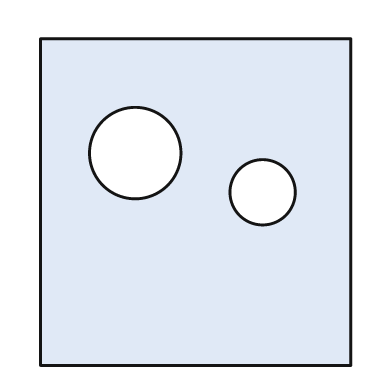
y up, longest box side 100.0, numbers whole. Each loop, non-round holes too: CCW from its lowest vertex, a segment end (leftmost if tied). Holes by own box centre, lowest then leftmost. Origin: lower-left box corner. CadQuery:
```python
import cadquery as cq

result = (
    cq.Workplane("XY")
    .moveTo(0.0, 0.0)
    .lineTo(95.0, 0.0)
    .lineTo(95.0, 100.0)
    .lineTo(0.0, 100.0)
    .close()
    .moveTo(68.0, 53.0)
    .circle(10.0)
    .moveTo(29.0, 65.0)
    .circle(14.0)
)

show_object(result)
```